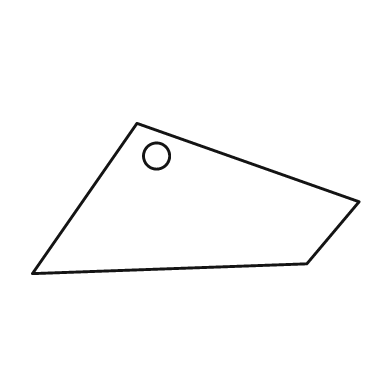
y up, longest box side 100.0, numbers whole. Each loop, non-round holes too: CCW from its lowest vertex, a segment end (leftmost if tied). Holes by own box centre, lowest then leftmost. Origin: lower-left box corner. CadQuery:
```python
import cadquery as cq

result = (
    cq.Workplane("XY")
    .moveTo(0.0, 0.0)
    .lineTo(84.0, 3.0)
    .lineTo(100.0, 22.0)
    .lineTo(32.0, 46.0)
    .close()
    .moveTo(38.0, 36.0)
    .circle(4.0)
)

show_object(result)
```